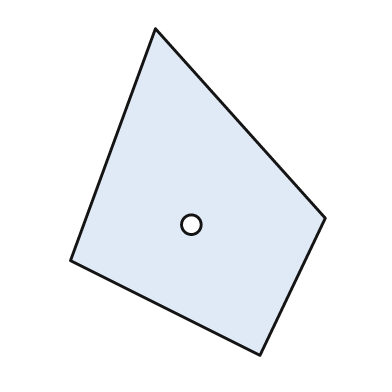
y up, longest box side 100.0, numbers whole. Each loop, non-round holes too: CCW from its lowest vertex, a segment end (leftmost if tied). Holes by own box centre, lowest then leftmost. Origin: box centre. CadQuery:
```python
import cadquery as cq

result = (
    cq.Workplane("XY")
    .moveTo(19.0, -50.0)
    .lineTo(39.0, -8.0)
    .lineTo(-13.0, 50.0)
    .lineTo(-39.0, -21.0)
    .close()
    .moveTo(-2.0, -10.0)
    .circle(3.0)
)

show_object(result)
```